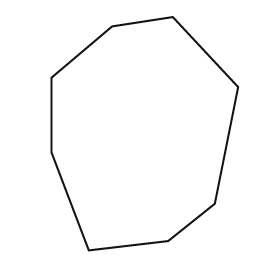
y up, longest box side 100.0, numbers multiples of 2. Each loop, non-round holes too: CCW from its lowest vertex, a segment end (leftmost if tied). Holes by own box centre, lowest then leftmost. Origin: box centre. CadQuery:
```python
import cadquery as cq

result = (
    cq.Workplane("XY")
    .moveTo(-24.0, -50.0)
    .lineTo(10.0, -46.0)
    .lineTo(30.0, -30.0)
    .lineTo(40.0, 20.0)
    .lineTo(12.0, 50.0)
    .lineTo(-14.0, 46.0)
    .lineTo(-40.0, 24.0)
    .lineTo(-40.0, -8.0)
    .close()
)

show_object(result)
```